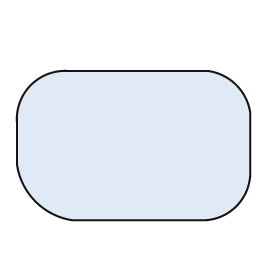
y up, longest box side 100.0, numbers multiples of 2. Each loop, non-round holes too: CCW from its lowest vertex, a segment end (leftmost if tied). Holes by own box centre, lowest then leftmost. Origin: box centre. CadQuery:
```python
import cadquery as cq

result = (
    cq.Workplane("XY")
    .moveTo(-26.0, -32.0)
    .lineTo(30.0, -32.0)
    .threePointArc((44.0, -26.0), (50.0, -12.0))
    .lineTo(50.0, 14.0)
    .threePointArc((44.0, 26.0), (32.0, 32.0))
    .lineTo(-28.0, 32.0)
    .threePointArc((-44.0, 26.0), (-50.0, 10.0))
    .lineTo(-50.0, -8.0)
    .threePointArc((-42.0, -24.0), (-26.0, -32.0))
    .close()
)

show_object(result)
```